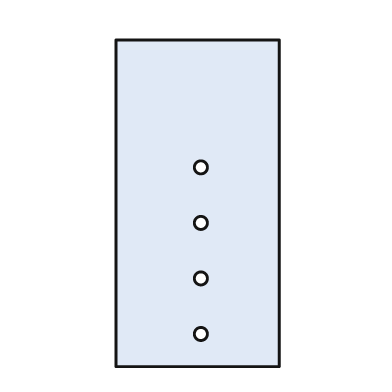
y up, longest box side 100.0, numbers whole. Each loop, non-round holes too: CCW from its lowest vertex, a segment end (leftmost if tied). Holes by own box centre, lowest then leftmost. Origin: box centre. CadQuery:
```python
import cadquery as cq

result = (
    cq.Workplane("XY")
    .moveTo(-25.0, -50.0)
    .lineTo(25.0, -50.0)
    .lineTo(25.0, 50.0)
    .lineTo(-25.0, 50.0)
    .close()
    .moveTo(1.0, -40.0)
    .circle(2.0)
    .moveTo(1.0, -23.0)
    .circle(2.0)
    .moveTo(1.0, -6.0)
    .circle(2.0)
    .moveTo(1.0, 11.0)
    .circle(2.0)
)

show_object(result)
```